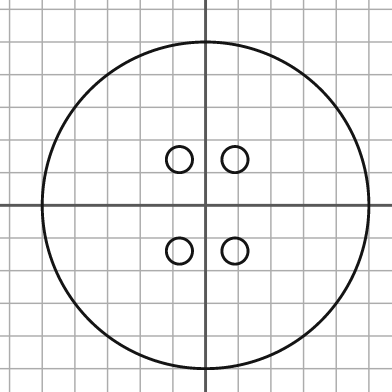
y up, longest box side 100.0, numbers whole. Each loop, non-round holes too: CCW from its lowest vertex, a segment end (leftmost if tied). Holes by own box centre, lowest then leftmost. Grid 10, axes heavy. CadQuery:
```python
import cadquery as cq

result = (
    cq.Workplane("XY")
    .moveTo(0.0, 0.0)
    .circle(50.0)
    .moveTo(-8.0, -14.0)
    .circle(4.0)
    .moveTo(9.0, -14.0)
    .circle(4.0)
    .moveTo(-8.0, 14.0)
    .circle(4.0)
    .moveTo(9.0, 14.0)
    .circle(4.0)
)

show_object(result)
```